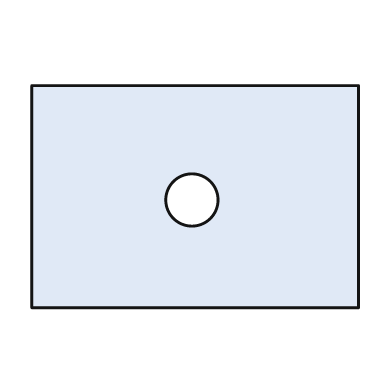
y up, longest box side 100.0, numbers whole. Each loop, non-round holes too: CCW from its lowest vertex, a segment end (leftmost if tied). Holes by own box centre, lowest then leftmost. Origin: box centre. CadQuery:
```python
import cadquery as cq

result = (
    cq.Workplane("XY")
    .moveTo(-50.0, -34.0)
    .lineTo(50.0, -34.0)
    .lineTo(50.0, 34.0)
    .lineTo(-50.0, 34.0)
    .close()
    .moveTo(-1.0, -1.0)
    .circle(8.0)
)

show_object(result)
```